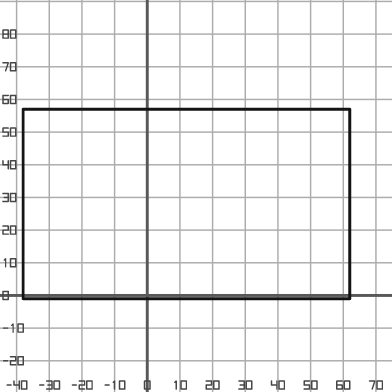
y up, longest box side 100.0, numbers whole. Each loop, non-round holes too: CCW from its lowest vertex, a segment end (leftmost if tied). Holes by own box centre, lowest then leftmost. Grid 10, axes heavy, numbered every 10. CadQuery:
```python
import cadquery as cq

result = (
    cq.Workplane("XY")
    .moveTo(-38.0, -1.0)
    .lineTo(62.0, -1.0)
    .lineTo(62.0, 57.0)
    .lineTo(-38.0, 57.0)
    .close()
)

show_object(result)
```